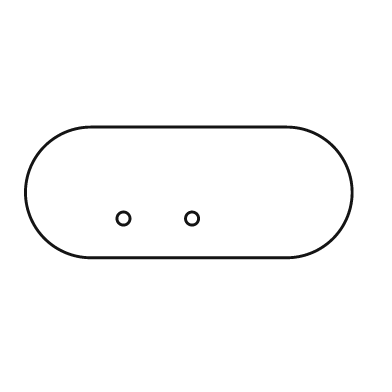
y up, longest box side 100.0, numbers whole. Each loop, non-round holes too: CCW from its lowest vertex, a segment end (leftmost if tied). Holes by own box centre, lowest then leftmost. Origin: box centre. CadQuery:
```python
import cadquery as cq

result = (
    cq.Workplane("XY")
    .moveTo(-30.0, -20.0)
    .lineTo(30.0, -20.0)
    .threePointArc((50.0, 0.0), (30.0, 20.0))
    .lineTo(-30.0, 20.0)
    .threePointArc((-50.0, 0.0), (-30.0, -20.0))
    .close()
    .moveTo(-20.0, -8.0)
    .circle(2.0)
    .moveTo(1.0, -8.0)
    .circle(2.0)
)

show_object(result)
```